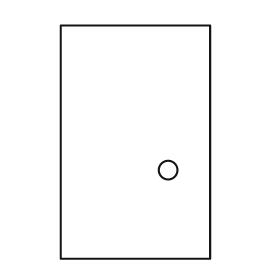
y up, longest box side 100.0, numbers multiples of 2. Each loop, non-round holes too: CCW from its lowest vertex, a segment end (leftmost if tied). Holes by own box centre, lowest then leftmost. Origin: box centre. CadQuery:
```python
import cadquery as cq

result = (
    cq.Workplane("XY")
    .moveTo(-32.0, -50.0)
    .lineTo(32.0, -50.0)
    .lineTo(32.0, 50.0)
    .lineTo(-32.0, 50.0)
    .close()
    .moveTo(14.0, -12.0)
    .circle(4.0)
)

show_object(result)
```